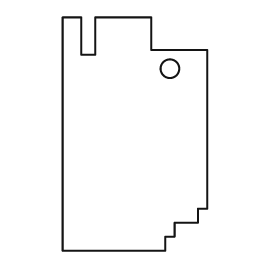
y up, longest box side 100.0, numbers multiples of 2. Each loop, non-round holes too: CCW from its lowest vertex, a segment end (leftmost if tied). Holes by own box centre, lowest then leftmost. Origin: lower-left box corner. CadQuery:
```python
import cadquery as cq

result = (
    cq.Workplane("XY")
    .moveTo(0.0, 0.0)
    .lineTo(44.0, 0.0)
    .lineTo(44.0, 6.0)
    .lineTo(48.0, 6.0)
    .lineTo(48.0, 12.0)
    .lineTo(58.0, 12.0)
    .lineTo(58.0, 18.0)
    .lineTo(62.0, 18.0)
    .lineTo(62.0, 86.0)
    .lineTo(38.0, 86.0)
    .lineTo(38.0, 100.0)
    .lineTo(14.0, 100.0)
    .lineTo(14.0, 84.0)
    .lineTo(8.0, 84.0)
    .lineTo(8.0, 100.0)
    .lineTo(0.0, 100.0)
    .close()
    .moveTo(46.0, 78.0)
    .circle(4.0)
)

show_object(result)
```